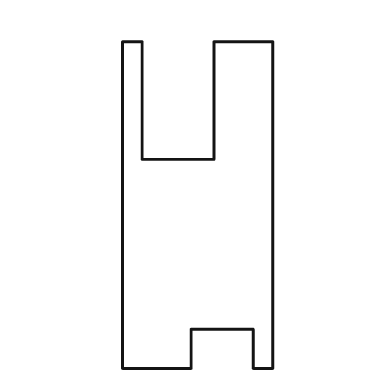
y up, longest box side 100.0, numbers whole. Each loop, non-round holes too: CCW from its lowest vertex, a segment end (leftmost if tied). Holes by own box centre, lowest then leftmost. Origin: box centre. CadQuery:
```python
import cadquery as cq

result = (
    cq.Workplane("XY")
    .moveTo(-23.0, -50.0)
    .lineTo(-2.0, -50.0)
    .lineTo(-2.0, -38.0)
    .lineTo(17.0, -38.0)
    .lineTo(17.0, -50.0)
    .lineTo(23.0, -50.0)
    .lineTo(23.0, 50.0)
    .lineTo(5.0, 50.0)
    .lineTo(5.0, 14.0)
    .lineTo(-17.0, 14.0)
    .lineTo(-17.0, 50.0)
    .lineTo(-23.0, 50.0)
    .close()
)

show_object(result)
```